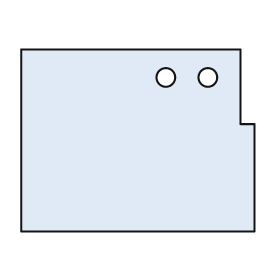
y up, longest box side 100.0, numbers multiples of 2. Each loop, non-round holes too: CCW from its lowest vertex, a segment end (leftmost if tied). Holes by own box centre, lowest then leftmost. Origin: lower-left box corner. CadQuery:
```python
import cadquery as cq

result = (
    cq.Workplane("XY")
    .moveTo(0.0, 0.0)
    .lineTo(100.0, 0.0)
    .lineTo(100.0, 46.0)
    .lineTo(94.0, 46.0)
    .lineTo(94.0, 78.0)
    .lineTo(0.0, 78.0)
    .close()
    .moveTo(62.0, 66.0)
    .circle(4.0)
    .moveTo(80.0, 66.0)
    .circle(4.0)
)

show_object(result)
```